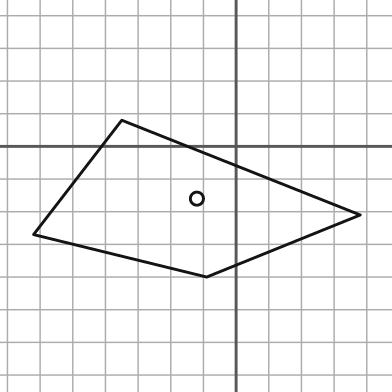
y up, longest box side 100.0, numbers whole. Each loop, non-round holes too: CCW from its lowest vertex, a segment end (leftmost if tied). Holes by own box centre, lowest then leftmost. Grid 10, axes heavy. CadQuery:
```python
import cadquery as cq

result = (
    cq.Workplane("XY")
    .moveTo(-9.0, -40.0)
    .lineTo(38.0, -21.0)
    .lineTo(-35.0, 8.0)
    .lineTo(-62.0, -27.0)
    .close()
    .moveTo(-12.0, -16.0)
    .circle(2.0)
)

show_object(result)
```